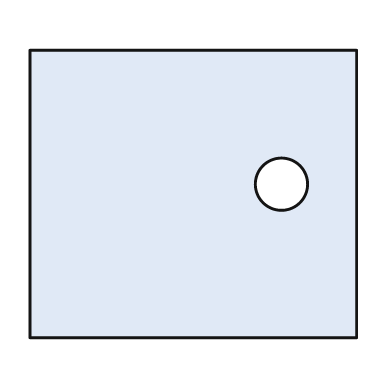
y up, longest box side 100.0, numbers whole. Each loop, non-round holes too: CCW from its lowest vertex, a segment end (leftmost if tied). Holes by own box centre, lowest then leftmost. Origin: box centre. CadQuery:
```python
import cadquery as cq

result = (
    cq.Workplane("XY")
    .moveTo(-50.0, -44.0)
    .lineTo(50.0, -44.0)
    .lineTo(50.0, 44.0)
    .lineTo(-50.0, 44.0)
    .close()
    .moveTo(27.0, 3.0)
    .circle(8.0)
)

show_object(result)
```